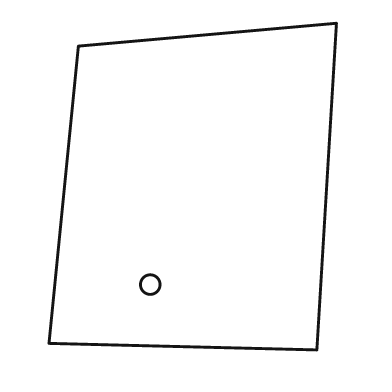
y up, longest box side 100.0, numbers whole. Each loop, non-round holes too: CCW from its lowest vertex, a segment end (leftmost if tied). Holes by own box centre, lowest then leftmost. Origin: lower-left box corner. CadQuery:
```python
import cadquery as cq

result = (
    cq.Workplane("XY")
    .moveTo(82.0, 0.0)
    .lineTo(88.0, 100.0)
    .lineTo(9.0, 93.0)
    .lineTo(0.0, 2.0)
    .close()
    .moveTo(31.0, 20.0)
    .circle(3.0)
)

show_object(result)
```